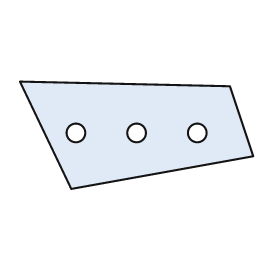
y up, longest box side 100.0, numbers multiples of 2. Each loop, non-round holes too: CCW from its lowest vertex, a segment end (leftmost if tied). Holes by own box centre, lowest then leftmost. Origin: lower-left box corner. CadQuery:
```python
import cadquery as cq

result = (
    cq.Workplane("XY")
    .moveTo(22.0, 0.0)
    .lineTo(100.0, 14.0)
    .lineTo(90.0, 44.0)
    .lineTo(0.0, 46.0)
    .close()
    .moveTo(24.0, 24.0)
    .circle(4.0)
    .moveTo(50.0, 24.0)
    .circle(4.0)
    .moveTo(76.0, 24.0)
    .circle(4.0)
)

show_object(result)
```